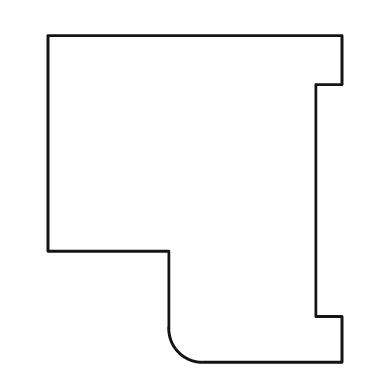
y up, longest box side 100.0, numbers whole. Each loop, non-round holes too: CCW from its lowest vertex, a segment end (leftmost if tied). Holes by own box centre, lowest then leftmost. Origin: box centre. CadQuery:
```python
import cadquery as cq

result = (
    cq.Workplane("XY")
    .moveTo(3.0, -50.0)
    .lineTo(45.0, -50.0)
    .lineTo(45.0, -36.0)
    .lineTo(37.0, -36.0)
    .lineTo(37.0, 35.0)
    .lineTo(45.0, 35.0)
    .lineTo(45.0, 50.0)
    .lineTo(-45.0, 50.0)
    .lineTo(-45.0, -16.0)
    .lineTo(-8.0, -16.0)
    .lineTo(-8.0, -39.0)
    .threePointArc((-5.0, -47.0), (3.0, -50.0))
    .close()
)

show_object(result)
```